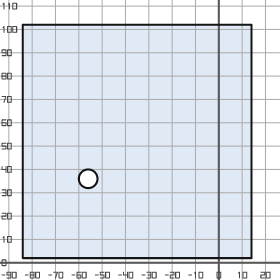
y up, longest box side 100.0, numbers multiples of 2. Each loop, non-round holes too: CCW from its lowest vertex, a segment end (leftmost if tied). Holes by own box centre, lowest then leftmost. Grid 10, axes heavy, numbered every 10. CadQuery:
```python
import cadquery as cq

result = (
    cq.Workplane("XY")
    .moveTo(-84.0, 2.0)
    .lineTo(14.0, 2.0)
    .lineTo(14.0, 102.0)
    .lineTo(-84.0, 102.0)
    .close()
    .moveTo(-56.0, 36.0)
    .circle(4.0)
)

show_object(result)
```